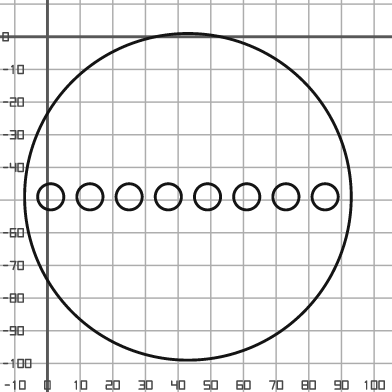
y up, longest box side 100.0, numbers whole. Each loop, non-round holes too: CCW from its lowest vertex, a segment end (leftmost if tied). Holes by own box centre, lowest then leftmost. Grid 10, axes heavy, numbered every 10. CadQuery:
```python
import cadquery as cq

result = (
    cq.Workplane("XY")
    .moveTo(43.0, -49.0)
    .circle(50.0)
    .moveTo(1.0, -49.0)
    .circle(4.0)
    .moveTo(13.0, -49.0)
    .circle(4.0)
    .moveTo(25.0, -49.0)
    .circle(4.0)
    .moveTo(37.0, -49.0)
    .circle(4.0)
    .moveTo(49.0, -49.0)
    .circle(4.0)
    .moveTo(61.0, -49.0)
    .circle(4.0)
    .moveTo(73.0, -49.0)
    .circle(4.0)
    .moveTo(85.0, -49.0)
    .circle(4.0)
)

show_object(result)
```